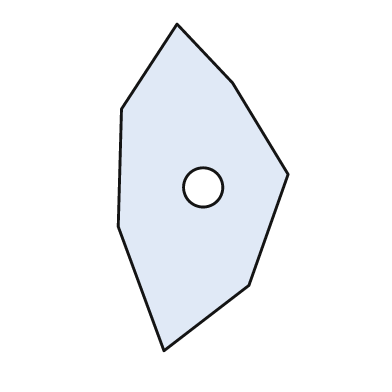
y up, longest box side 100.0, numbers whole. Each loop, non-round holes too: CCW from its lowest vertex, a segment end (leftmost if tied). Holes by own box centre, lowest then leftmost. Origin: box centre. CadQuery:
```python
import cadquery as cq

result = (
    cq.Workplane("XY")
    .moveTo(-12.0, -50.0)
    .lineTo(14.0, -30.0)
    .lineTo(26.0, 4.0)
    .lineTo(9.0, 32.0)
    .lineTo(-8.0, 50.0)
    .lineTo(-25.0, 24.0)
    .lineTo(-26.0, -12.0)
    .close()
    .moveTo(0.0, 0.0)
    .circle(6.0)
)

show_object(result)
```